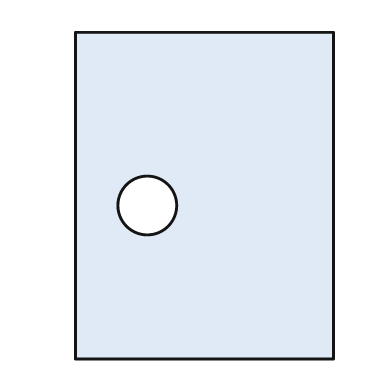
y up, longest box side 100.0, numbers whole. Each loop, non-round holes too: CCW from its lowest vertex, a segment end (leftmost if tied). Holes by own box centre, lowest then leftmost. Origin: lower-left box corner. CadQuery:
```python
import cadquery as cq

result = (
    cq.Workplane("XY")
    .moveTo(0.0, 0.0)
    .lineTo(79.0, 0.0)
    .lineTo(79.0, 100.0)
    .lineTo(0.0, 100.0)
    .close()
    .moveTo(22.0, 47.0)
    .circle(9.0)
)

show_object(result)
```